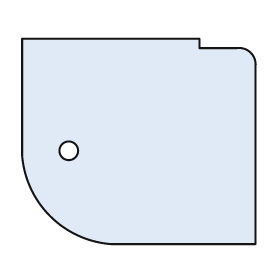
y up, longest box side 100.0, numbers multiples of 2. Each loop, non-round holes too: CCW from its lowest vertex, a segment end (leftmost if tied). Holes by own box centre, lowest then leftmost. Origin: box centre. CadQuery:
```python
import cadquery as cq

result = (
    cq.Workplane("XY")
    .moveTo(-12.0, -44.0)
    .lineTo(50.0, -44.0)
    .lineTo(50.0, 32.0)
    .threePointArc((48.0, 38.0), (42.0, 40.0))
    .lineTo(26.0, 40.0)
    .lineTo(26.0, 44.0)
    .lineTo(-50.0, 44.0)
    .lineTo(-50.0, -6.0)
    .threePointArc((-38.0, -32.0), (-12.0, -44.0))
    .close()
    .moveTo(-30.0, -4.0)
    .circle(4.0)
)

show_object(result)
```